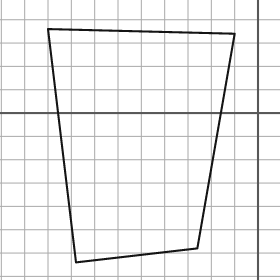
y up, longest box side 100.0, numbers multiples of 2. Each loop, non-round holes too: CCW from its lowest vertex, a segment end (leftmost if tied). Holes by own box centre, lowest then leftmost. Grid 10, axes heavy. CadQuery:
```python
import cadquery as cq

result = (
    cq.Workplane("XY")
    .moveTo(-78.0, -64.0)
    .lineTo(-26.0, -58.0)
    .lineTo(-10.0, 34.0)
    .lineTo(-90.0, 36.0)
    .close()
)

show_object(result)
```